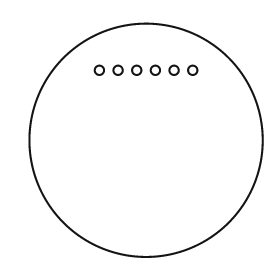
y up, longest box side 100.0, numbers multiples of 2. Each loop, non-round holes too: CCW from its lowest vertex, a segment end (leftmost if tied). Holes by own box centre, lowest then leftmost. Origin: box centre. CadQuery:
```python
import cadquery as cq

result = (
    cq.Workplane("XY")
    .moveTo(0.0, 0.0)
    .circle(50.0)
    .moveTo(-20.0, 30.0)
    .circle(2.0)
    .moveTo(-12.0, 30.0)
    .circle(2.0)
    .moveTo(-4.0, 30.0)
    .circle(2.0)
    .moveTo(4.0, 30.0)
    .circle(2.0)
    .moveTo(12.0, 30.0)
    .circle(2.0)
    .moveTo(20.0, 30.0)
    .circle(2.0)
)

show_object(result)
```